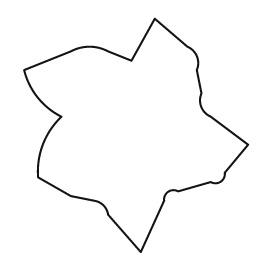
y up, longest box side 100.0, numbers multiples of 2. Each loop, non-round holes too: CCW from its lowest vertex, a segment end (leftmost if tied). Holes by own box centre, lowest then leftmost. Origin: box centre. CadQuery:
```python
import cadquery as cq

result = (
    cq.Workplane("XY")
    .moveTo(2.0, -50.0)
    .lineTo(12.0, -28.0)
    .threePointArc((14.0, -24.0), (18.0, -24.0))
    .lineTo(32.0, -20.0)
    .threePointArc((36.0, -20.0), (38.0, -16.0))
    .lineTo(48.0, -4.0)
    .lineTo(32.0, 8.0)
    .threePointArc((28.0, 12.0), (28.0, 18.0))
    .lineTo(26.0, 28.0)
    .threePointArc((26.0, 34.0), (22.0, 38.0))
    .lineTo(8.0, 50.0)
    .lineTo(-2.0, 32.0)
    .lineTo(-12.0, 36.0)
    .threePointArc((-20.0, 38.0), (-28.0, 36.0))
    .lineTo(-48.0, 28.0)
    .threePointArc((-42.0, 16.0), (-32.0, 8.0))
    .threePointArc((-40.0, -4.0), (-42.0, -18.0))
    .lineTo(-28.0, -26.0)
    .lineTo(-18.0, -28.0)
    .threePointArc((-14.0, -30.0), (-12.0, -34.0))
    .close()
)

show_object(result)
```